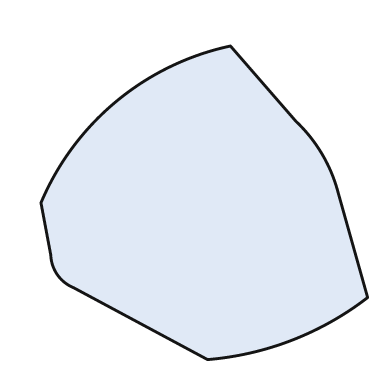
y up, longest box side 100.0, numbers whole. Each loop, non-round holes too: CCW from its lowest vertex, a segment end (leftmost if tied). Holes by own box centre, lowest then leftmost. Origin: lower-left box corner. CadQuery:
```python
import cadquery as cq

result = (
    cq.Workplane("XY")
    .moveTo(51.0, 0.0)
    .threePointArc((77.0, 6.0), (100.0, 19.0))
    .lineTo(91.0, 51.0)
    .threePointArc((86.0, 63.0), (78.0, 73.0))
    .lineTo(58.0, 96.0)
    .threePointArc((23.0, 79.0), (0.0, 48.0))
    .lineTo(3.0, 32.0)
    .threePointArc((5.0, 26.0), (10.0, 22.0))
    .close()
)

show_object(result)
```